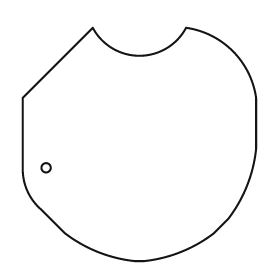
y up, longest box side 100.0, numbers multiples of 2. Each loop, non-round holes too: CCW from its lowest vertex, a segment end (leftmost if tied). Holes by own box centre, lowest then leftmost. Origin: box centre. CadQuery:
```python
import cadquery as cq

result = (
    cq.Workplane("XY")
    .moveTo(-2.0, -50.0)
    .lineTo(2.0, -50.0)
    .threePointArc((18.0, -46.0), (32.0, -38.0))
    .lineTo(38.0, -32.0)
    .threePointArc((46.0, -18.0), (50.0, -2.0))
    .lineTo(50.0, 20.0)
    .threePointArc((40.0, 40.0), (20.0, 50.0))
    .threePointArc((0.0, 38.0), (-20.0, 50.0))
    .lineTo(-50.0, 20.0)
    .lineTo(-50.0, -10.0)
    .threePointArc((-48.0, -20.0), (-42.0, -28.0))
    .lineTo(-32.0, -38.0)
    .threePointArc((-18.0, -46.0), (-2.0, -50.0))
    .close()
    .moveTo(-40.0, -10.0)
    .circle(2.0)
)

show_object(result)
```